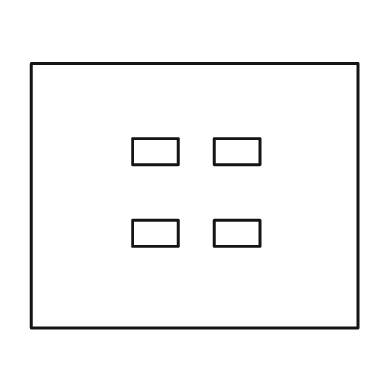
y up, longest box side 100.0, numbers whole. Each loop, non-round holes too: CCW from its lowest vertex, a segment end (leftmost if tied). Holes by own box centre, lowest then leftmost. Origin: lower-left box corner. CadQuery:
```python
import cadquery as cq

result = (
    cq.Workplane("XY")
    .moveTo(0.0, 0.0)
    .lineTo(100.0, 0.0)
    .lineTo(100.0, 81.0)
    .lineTo(0.0, 81.0)
    .close()
    .moveTo(31.0, 25.0)
    .lineTo(45.0, 25.0)
    .lineTo(45.0, 33.0)
    .lineTo(31.0, 33.0)
    .close()
    .moveTo(56.0, 25.0)
    .lineTo(70.0, 25.0)
    .lineTo(70.0, 33.0)
    .lineTo(56.0, 33.0)
    .close()
    .moveTo(31.0, 50.0)
    .lineTo(45.0, 50.0)
    .lineTo(45.0, 58.0)
    .lineTo(31.0, 58.0)
    .close()
    .moveTo(56.0, 50.0)
    .lineTo(70.0, 50.0)
    .lineTo(70.0, 58.0)
    .lineTo(56.0, 58.0)
    .close()
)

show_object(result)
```